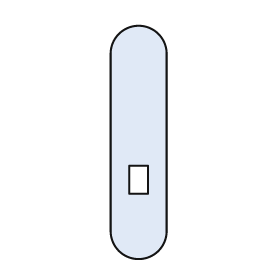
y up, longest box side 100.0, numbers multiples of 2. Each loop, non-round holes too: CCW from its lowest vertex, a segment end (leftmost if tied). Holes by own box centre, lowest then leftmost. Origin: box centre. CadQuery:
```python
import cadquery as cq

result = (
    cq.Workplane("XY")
    .moveTo(-12.0, -38.0)
    .threePointArc((0.0, -50.0), (12.0, -38.0))
    .lineTo(12.0, 38.0)
    .threePointArc((0.0, 50.0), (-12.0, 38.0))
    .close()
    .moveTo(-4.0, -22.0)
    .lineTo(4.0, -22.0)
    .lineTo(4.0, -10.0)
    .lineTo(-4.0, -10.0)
    .close()
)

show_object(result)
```